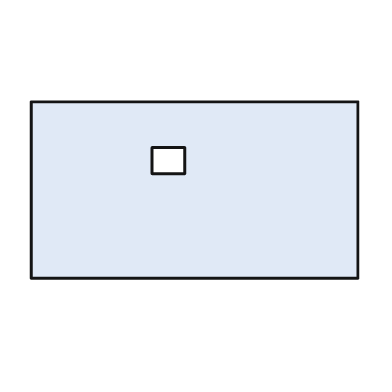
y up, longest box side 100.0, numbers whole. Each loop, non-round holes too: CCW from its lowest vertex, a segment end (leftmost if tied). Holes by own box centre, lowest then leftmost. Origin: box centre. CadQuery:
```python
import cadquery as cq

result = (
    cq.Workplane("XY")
    .moveTo(-50.0, -27.0)
    .lineTo(50.0, -27.0)
    .lineTo(50.0, 27.0)
    .lineTo(-50.0, 27.0)
    .close()
    .moveTo(-13.0, 5.0)
    .lineTo(-3.0, 5.0)
    .lineTo(-3.0, 13.0)
    .lineTo(-13.0, 13.0)
    .close()
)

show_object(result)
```